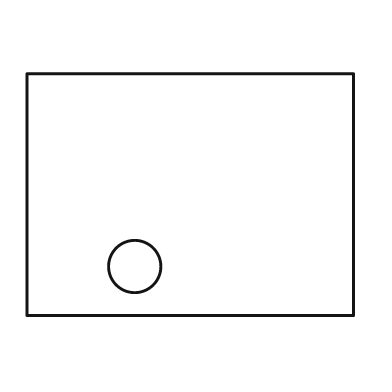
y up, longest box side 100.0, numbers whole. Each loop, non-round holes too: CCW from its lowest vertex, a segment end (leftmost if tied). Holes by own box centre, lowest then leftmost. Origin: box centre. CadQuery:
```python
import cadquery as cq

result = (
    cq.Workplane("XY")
    .moveTo(-50.0, -37.0)
    .lineTo(50.0, -37.0)
    .lineTo(50.0, 37.0)
    .lineTo(-50.0, 37.0)
    .close()
    .moveTo(-17.0, -22.0)
    .circle(8.0)
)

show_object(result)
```